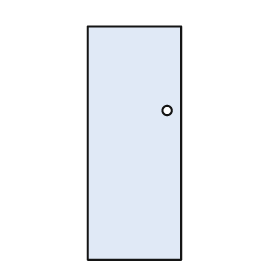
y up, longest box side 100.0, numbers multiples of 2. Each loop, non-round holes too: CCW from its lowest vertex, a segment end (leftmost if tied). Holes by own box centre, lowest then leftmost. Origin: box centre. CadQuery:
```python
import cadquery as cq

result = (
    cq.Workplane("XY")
    .moveTo(-20.0, -50.0)
    .lineTo(20.0, -50.0)
    .lineTo(20.0, 50.0)
    .lineTo(-20.0, 50.0)
    .close()
    .moveTo(14.0, 14.0)
    .circle(2.0)
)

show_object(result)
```